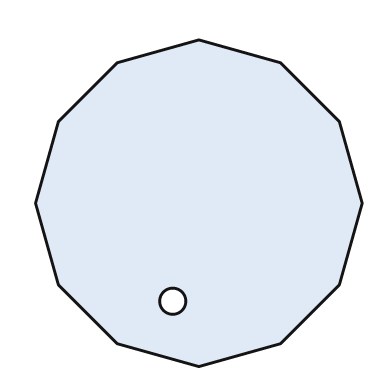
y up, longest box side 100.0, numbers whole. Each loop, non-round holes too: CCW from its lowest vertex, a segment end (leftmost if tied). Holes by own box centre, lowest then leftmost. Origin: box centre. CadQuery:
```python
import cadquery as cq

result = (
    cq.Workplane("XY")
    .moveTo(0.0, -50.0)
    .lineTo(25.0, -43.0)
    .lineTo(43.0, -25.0)
    .lineTo(50.0, 0.0)
    .lineTo(43.0, 25.0)
    .lineTo(25.0, 43.0)
    .lineTo(0.0, 50.0)
    .lineTo(-25.0, 43.0)
    .lineTo(-43.0, 25.0)
    .lineTo(-50.0, 0.0)
    .lineTo(-43.0, -25.0)
    .lineTo(-25.0, -43.0)
    .close()
    .moveTo(-8.0, -30.0)
    .circle(4.0)
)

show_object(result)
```